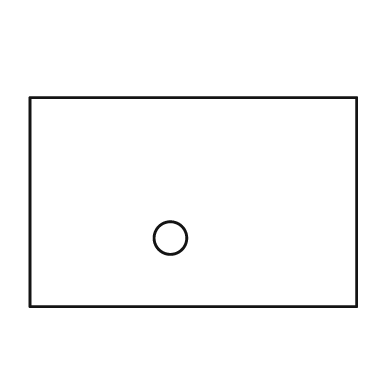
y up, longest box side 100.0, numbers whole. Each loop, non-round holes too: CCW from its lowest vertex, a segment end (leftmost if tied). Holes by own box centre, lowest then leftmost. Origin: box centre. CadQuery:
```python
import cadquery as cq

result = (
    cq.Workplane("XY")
    .moveTo(-50.0, -32.0)
    .lineTo(50.0, -32.0)
    .lineTo(50.0, 32.0)
    .lineTo(-50.0, 32.0)
    .close()
    .moveTo(-7.0, -11.0)
    .circle(5.0)
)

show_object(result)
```